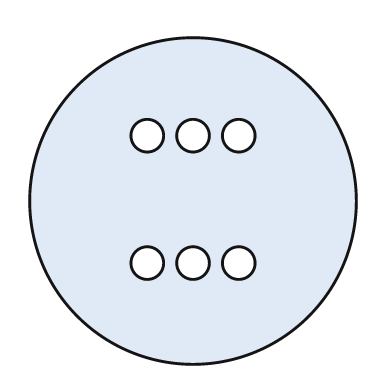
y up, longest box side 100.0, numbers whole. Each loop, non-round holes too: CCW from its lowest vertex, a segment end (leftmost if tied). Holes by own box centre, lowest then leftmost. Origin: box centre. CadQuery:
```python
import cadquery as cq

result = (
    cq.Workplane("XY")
    .moveTo(0.0, 0.0)
    .circle(50.0)
    .moveTo(-14.0, -19.0)
    .circle(5.0)
    .moveTo(0.0, -19.0)
    .circle(5.0)
    .moveTo(14.0, -19.0)
    .circle(5.0)
    .moveTo(-14.0, 20.0)
    .circle(5.0)
    .moveTo(0.0, 20.0)
    .circle(5.0)
    .moveTo(14.0, 20.0)
    .circle(5.0)
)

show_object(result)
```